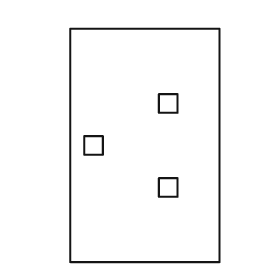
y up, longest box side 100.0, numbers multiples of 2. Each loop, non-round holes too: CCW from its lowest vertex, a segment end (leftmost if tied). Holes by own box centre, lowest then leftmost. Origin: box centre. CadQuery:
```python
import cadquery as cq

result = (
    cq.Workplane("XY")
    .moveTo(-32.0, -50.0)
    .lineTo(32.0, -50.0)
    .lineTo(32.0, 50.0)
    .lineTo(-32.0, 50.0)
    .close()
    .moveTo(6.0, -22.0)
    .lineTo(14.0, -22.0)
    .lineTo(14.0, -14.0)
    .lineTo(6.0, -14.0)
    .close()
    .moveTo(-26.0, -4.0)
    .lineTo(-18.0, -4.0)
    .lineTo(-18.0, 4.0)
    .lineTo(-26.0, 4.0)
    .close()
    .moveTo(6.0, 14.0)
    .lineTo(14.0, 14.0)
    .lineTo(14.0, 22.0)
    .lineTo(6.0, 22.0)
    .close()
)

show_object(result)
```